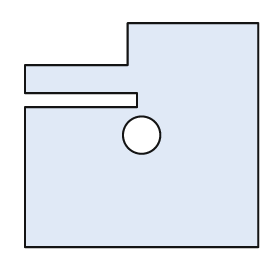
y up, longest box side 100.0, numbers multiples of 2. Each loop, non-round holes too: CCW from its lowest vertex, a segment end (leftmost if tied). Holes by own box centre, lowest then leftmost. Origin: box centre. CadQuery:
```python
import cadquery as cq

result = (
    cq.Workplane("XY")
    .moveTo(-50.0, -48.0)
    .lineTo(50.0, -48.0)
    .lineTo(50.0, 48.0)
    .lineTo(-6.0, 48.0)
    .lineTo(-6.0, 30.0)
    .lineTo(-50.0, 30.0)
    .lineTo(-50.0, 18.0)
    .lineTo(-2.0, 18.0)
    .lineTo(-2.0, 12.0)
    .lineTo(-50.0, 12.0)
    .close()
    .moveTo(0.0, 0.0)
    .circle(8.0)
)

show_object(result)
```